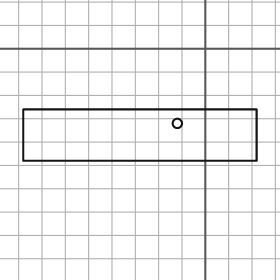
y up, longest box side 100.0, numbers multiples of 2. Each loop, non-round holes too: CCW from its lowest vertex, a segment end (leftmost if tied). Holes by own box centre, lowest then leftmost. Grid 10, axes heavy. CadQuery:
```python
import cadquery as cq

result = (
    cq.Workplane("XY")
    .moveTo(-78.0, -48.0)
    .lineTo(22.0, -48.0)
    .lineTo(22.0, -26.0)
    .lineTo(-78.0, -26.0)
    .close()
    .moveTo(-12.0, -32.0)
    .circle(2.0)
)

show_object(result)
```